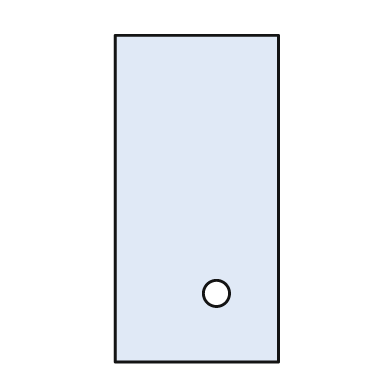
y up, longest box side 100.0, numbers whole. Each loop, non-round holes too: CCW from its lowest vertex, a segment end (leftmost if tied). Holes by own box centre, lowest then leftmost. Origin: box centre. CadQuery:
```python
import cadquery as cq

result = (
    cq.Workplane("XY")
    .moveTo(-25.0, -50.0)
    .lineTo(25.0, -50.0)
    .lineTo(25.0, 50.0)
    .lineTo(-25.0, 50.0)
    .close()
    .moveTo(6.0, -29.0)
    .circle(4.0)
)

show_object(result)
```